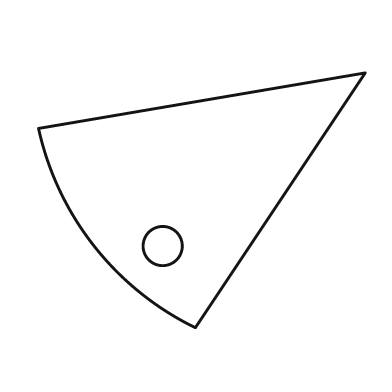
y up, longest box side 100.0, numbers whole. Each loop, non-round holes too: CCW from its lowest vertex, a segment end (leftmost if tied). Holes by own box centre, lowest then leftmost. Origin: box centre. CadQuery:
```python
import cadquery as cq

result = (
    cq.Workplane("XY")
    .moveTo(-2.0, -39.0)
    .lineTo(50.0, 39.0)
    .lineTo(-50.0, 22.0)
    .threePointArc((-33.0, -14.0), (-2.0, -39.0))
    .close()
    .moveTo(-12.0, -14.0)
    .circle(6.0)
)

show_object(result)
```